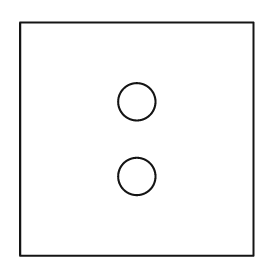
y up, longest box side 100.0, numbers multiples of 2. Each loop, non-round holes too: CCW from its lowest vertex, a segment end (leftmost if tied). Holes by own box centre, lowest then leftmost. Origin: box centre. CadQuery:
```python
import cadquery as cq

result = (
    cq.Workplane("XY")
    .moveTo(-50.0, -50.0)
    .lineTo(50.0, -50.0)
    .lineTo(50.0, 50.0)
    .lineTo(-50.0, 50.0)
    .close()
    .moveTo(0.0, -16.0)
    .circle(8.0)
    .moveTo(0.0, 16.0)
    .circle(8.0)
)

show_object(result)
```